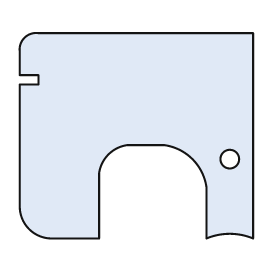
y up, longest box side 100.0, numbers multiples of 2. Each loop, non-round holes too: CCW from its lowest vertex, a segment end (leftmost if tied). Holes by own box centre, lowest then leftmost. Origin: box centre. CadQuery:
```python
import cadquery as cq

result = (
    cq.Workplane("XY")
    .moveTo(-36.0, -44.0)
    .lineTo(-16.0, -44.0)
    .lineTo(-16.0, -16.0)
    .threePointArc((-12.0, -8.0), (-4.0, -4.0))
    .lineTo(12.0, -4.0)
    .threePointArc((24.0, -10.0), (30.0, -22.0))
    .lineTo(30.0, -44.0)
    .threePointArc((40.0, -42.0), (50.0, -44.0))
    .lineTo(50.0, 44.0)
    .lineTo(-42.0, 44.0)
    .threePointArc((-48.0, 42.0), (-50.0, 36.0))
    .lineTo(-50.0, 26.0)
    .lineTo(-42.0, 26.0)
    .lineTo(-42.0, 22.0)
    .lineTo(-50.0, 22.0)
    .lineTo(-50.0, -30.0)
    .threePointArc((-46.0, -40.0), (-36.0, -44.0))
    .close()
    .moveTo(40.0, -10.0)
    .circle(4.0)
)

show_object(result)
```